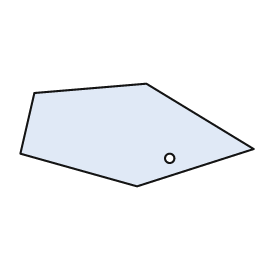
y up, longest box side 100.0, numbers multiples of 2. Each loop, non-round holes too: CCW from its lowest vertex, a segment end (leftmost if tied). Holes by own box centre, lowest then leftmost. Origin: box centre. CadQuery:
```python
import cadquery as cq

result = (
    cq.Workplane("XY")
    .moveTo(0.0, -22.0)
    .lineTo(50.0, -6.0)
    .lineTo(4.0, 22.0)
    .lineTo(-44.0, 18.0)
    .lineTo(-50.0, -8.0)
    .close()
    .moveTo(14.0, -10.0)
    .circle(2.0)
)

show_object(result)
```